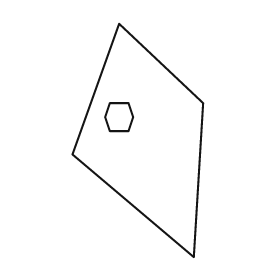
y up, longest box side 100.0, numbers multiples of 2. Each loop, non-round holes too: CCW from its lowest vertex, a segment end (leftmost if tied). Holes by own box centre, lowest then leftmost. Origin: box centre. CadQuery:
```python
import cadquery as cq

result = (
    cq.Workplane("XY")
    .moveTo(24.0, -50.0)
    .lineTo(28.0, 16.0)
    .lineTo(-8.0, 50.0)
    .lineTo(-28.0, -6.0)
    .close()
    .moveTo(-12.0, 4.0)
    .lineTo(-4.0, 4.0)
    .lineTo(-2.0, 10.0)
    .lineTo(-4.0, 16.0)
    .lineTo(-12.0, 16.0)
    .lineTo(-14.0, 10.0)
    .close()
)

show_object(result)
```